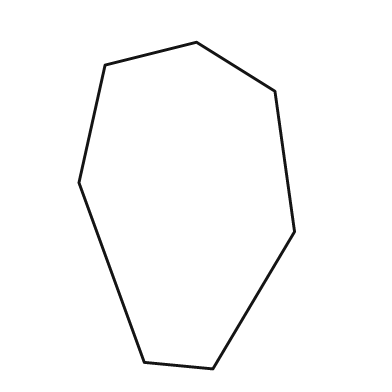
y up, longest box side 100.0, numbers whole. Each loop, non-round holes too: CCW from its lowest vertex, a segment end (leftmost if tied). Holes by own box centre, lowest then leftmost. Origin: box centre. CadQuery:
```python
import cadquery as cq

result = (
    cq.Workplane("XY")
    .moveTo(8.0, -50.0)
    .lineTo(33.0, -8.0)
    .lineTo(27.0, 35.0)
    .lineTo(3.0, 50.0)
    .lineTo(-25.0, 43.0)
    .lineTo(-33.0, 7.0)
    .lineTo(-13.0, -48.0)
    .close()
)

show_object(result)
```